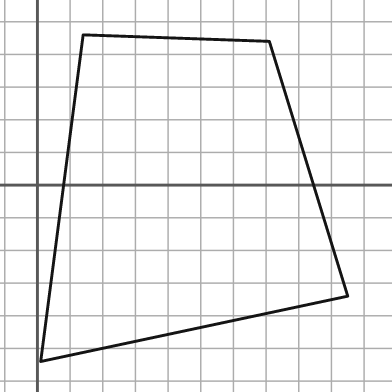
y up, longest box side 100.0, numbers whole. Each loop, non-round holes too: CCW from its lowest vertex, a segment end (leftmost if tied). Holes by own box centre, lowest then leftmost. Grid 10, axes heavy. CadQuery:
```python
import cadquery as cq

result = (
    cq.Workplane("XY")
    .moveTo(1.0, -54.0)
    .lineTo(95.0, -34.0)
    .lineTo(71.0, 44.0)
    .lineTo(14.0, 46.0)
    .close()
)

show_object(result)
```